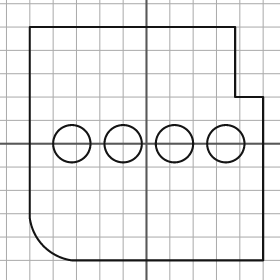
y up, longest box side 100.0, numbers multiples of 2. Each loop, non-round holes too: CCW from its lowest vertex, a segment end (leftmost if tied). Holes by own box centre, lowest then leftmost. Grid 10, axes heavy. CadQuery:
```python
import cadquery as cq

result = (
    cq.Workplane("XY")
    .moveTo(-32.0, -50.0)
    .lineTo(50.0, -50.0)
    .lineTo(50.0, 20.0)
    .lineTo(38.0, 20.0)
    .lineTo(38.0, 50.0)
    .lineTo(-50.0, 50.0)
    .lineTo(-50.0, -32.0)
    .threePointArc((-44.0, -44.0), (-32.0, -50.0))
    .close()
    .moveTo(-32.0, 0.0)
    .circle(8.0)
    .moveTo(-10.0, 0.0)
    .circle(8.0)
    .moveTo(12.0, 0.0)
    .circle(8.0)
    .moveTo(34.0, 0.0)
    .circle(8.0)
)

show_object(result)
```